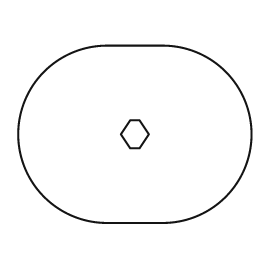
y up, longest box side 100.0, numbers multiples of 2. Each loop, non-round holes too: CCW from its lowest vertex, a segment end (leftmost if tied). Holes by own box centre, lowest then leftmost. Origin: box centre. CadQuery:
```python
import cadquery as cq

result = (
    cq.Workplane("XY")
    .moveTo(-12.0, -38.0)
    .lineTo(12.0, -38.0)
    .threePointArc((50.0, 0.0), (12.0, 38.0))
    .lineTo(-12.0, 38.0)
    .threePointArc((-50.0, 0.0), (-12.0, -38.0))
    .close()
    .moveTo(-2.0, -6.0)
    .lineTo(2.0, -6.0)
    .lineTo(6.0, 0.0)
    .lineTo(2.0, 6.0)
    .lineTo(-2.0, 6.0)
    .lineTo(-6.0, 0.0)
    .close()
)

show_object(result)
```